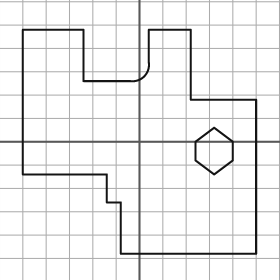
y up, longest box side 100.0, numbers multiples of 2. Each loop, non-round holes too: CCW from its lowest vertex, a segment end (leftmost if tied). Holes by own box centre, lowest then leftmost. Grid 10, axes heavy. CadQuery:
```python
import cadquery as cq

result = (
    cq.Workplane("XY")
    .moveTo(-8.0, -48.0)
    .lineTo(50.0, -48.0)
    .lineTo(50.0, 18.0)
    .lineTo(22.0, 18.0)
    .lineTo(22.0, 48.0)
    .lineTo(4.0, 48.0)
    .lineTo(4.0, 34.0)
    .threePointArc((2.0, 28.0), (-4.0, 26.0))
    .lineTo(-24.0, 26.0)
    .lineTo(-24.0, 48.0)
    .lineTo(-50.0, 48.0)
    .lineTo(-50.0, -14.0)
    .lineTo(-14.0, -14.0)
    .lineTo(-14.0, -26.0)
    .lineTo(-8.0, -26.0)
    .close()
    .moveTo(32.0, -14.0)
    .lineTo(40.0, -8.0)
    .lineTo(40.0, 0.0)
    .lineTo(32.0, 6.0)
    .lineTo(24.0, 0.0)
    .lineTo(24.0, -8.0)
    .close()
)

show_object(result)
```